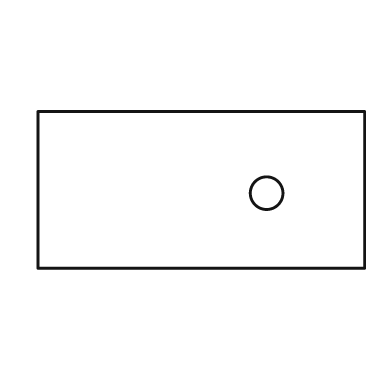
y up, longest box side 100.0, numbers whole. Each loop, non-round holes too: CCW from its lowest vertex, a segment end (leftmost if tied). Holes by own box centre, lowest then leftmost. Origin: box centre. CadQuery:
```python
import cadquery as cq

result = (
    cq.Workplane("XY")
    .moveTo(-50.0, -24.0)
    .lineTo(50.0, -24.0)
    .lineTo(50.0, 24.0)
    .lineTo(-50.0, 24.0)
    .close()
    .moveTo(20.0, -1.0)
    .circle(5.0)
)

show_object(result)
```